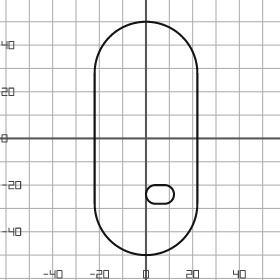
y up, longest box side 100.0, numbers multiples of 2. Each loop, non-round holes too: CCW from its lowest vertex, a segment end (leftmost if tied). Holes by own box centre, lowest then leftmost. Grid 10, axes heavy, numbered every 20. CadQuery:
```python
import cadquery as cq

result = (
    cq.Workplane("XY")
    .moveTo(-22.0, -28.0)
    .threePointArc((0.0, -50.0), (22.0, -28.0))
    .lineTo(22.0, 28.0)
    .threePointArc((0.0, 50.0), (-22.0, 28.0))
    .close()
    .moveTo(4.0, -28.0)
    .lineTo(8.0, -28.0)
    .threePointArc((12.0, -24.0), (8.0, -20.0))
    .lineTo(4.0, -20.0)
    .threePointArc((0.0, -24.0), (4.0, -28.0))
    .close()
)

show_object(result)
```